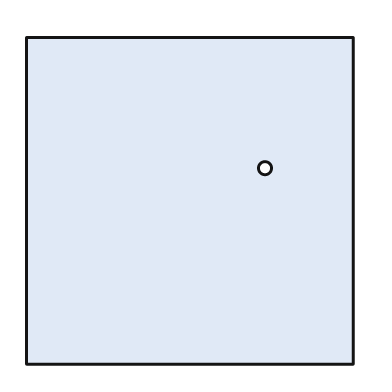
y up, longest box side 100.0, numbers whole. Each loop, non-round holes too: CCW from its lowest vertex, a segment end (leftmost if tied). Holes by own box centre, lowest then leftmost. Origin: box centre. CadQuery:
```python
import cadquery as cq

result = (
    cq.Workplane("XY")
    .moveTo(-50.0, -50.0)
    .lineTo(50.0, -50.0)
    .lineTo(50.0, 50.0)
    .lineTo(-50.0, 50.0)
    .close()
    .moveTo(23.0, 10.0)
    .circle(2.0)
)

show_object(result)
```